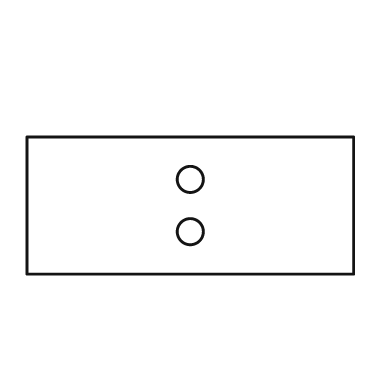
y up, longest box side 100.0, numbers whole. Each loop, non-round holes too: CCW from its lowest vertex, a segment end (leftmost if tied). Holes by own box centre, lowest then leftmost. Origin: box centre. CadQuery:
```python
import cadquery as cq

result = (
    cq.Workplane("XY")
    .moveTo(-50.0, -21.0)
    .lineTo(50.0, -21.0)
    .lineTo(50.0, 21.0)
    .lineTo(-50.0, 21.0)
    .close()
    .moveTo(0.0, -8.0)
    .circle(4.0)
    .moveTo(0.0, 8.0)
    .circle(4.0)
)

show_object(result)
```